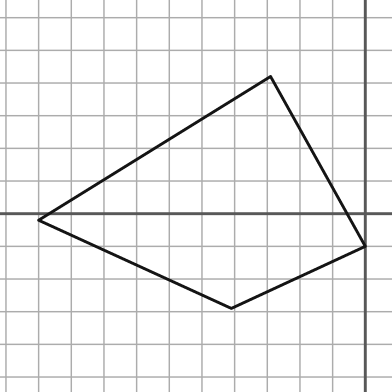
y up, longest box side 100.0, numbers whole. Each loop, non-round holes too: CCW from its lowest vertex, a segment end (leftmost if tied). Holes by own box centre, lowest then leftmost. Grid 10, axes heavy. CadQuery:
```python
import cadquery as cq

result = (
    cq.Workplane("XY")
    .moveTo(-41.0, -29.0)
    .lineTo(0.0, -10.0)
    .lineTo(-29.0, 42.0)
    .lineTo(-100.0, -2.0)
    .close()
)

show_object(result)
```